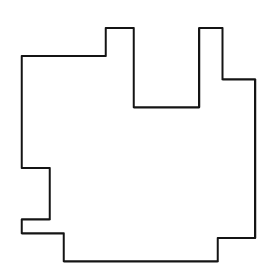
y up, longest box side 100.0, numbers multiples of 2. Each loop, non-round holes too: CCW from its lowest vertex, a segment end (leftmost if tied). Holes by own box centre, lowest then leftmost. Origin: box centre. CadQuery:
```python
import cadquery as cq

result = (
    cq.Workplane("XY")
    .moveTo(-32.0, -50.0)
    .lineTo(34.0, -50.0)
    .lineTo(34.0, -40.0)
    .lineTo(50.0, -40.0)
    .lineTo(50.0, 28.0)
    .lineTo(36.0, 28.0)
    .lineTo(36.0, 50.0)
    .lineTo(26.0, 50.0)
    .lineTo(26.0, 16.0)
    .lineTo(-2.0, 16.0)
    .lineTo(-2.0, 50.0)
    .lineTo(-14.0, 50.0)
    .lineTo(-14.0, 38.0)
    .lineTo(-50.0, 38.0)
    .lineTo(-50.0, -10.0)
    .lineTo(-38.0, -10.0)
    .lineTo(-38.0, -32.0)
    .lineTo(-50.0, -32.0)
    .lineTo(-50.0, -38.0)
    .lineTo(-32.0, -38.0)
    .close()
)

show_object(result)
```